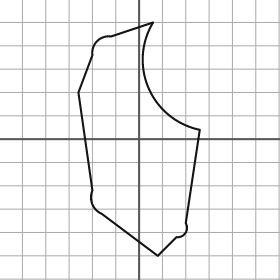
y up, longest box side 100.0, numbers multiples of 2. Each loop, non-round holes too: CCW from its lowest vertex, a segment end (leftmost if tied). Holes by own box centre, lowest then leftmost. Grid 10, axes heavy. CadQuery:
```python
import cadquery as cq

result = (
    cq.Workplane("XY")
    .moveTo(8.0, -50.0)
    .lineTo(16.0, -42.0)
    .threePointArc((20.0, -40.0), (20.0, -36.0))
    .lineTo(26.0, 4.0)
    .threePointArc((4.0, 22.0), (6.0, 50.0))
    .lineTo(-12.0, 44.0)
    .threePointArc((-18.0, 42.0), (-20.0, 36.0))
    .lineTo(-26.0, 20.0)
    .lineTo(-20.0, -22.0)
    .threePointArc((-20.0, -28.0), (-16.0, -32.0))
    .close()
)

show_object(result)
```